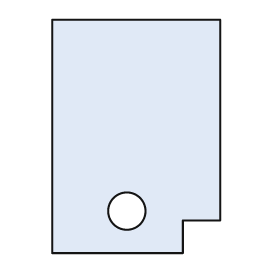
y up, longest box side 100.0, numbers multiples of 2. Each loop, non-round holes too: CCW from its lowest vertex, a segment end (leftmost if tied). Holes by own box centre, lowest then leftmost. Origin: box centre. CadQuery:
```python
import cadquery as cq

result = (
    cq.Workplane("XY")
    .moveTo(-36.0, -50.0)
    .lineTo(20.0, -50.0)
    .lineTo(20.0, -36.0)
    .lineTo(36.0, -36.0)
    .lineTo(36.0, 50.0)
    .lineTo(-36.0, 50.0)
    .close()
    .moveTo(-4.0, -32.0)
    .circle(8.0)
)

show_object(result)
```